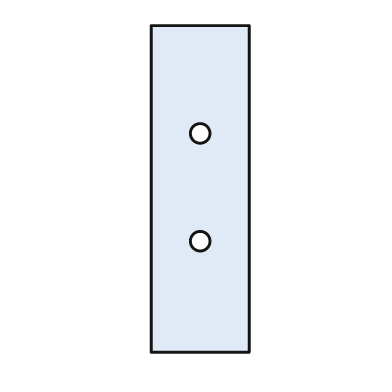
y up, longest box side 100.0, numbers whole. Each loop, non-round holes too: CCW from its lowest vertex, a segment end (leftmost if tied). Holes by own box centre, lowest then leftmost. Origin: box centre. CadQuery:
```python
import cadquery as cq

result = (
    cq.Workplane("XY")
    .moveTo(-15.0, -50.0)
    .lineTo(15.0, -50.0)
    .lineTo(15.0, 50.0)
    .lineTo(-15.0, 50.0)
    .close()
    .moveTo(0.0, -16.0)
    .circle(3.0)
    .moveTo(0.0, 17.0)
    .circle(3.0)
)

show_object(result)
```